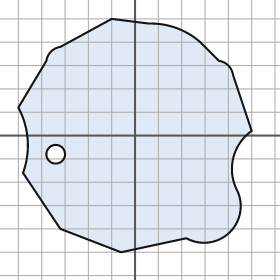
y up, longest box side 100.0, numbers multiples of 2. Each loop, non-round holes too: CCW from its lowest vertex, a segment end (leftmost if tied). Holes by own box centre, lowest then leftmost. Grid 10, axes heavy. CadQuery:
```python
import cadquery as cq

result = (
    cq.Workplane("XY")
    .moveTo(-6.0, -50.0)
    .lineTo(22.0, -44.0)
    .threePointArc((40.0, -42.0), (44.0, -24.0))
    .threePointArc((42.0, -10.0), (50.0, 2.0))
    .lineTo(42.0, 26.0)
    .threePointArc((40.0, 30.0), (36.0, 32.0))
    .lineTo(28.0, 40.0)
    .threePointArc((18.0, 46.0), (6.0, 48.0))
    .lineTo(-10.0, 50.0)
    .lineTo(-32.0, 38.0)
    .threePointArc((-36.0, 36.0), (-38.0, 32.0))
    .lineTo(-50.0, 12.0)
    .threePointArc((-46.0, -2.0), (-48.0, -16.0))
    .lineTo(-32.0, -40.0)
    .close()
    .moveTo(-34.0, -8.0)
    .circle(4.0)
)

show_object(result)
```